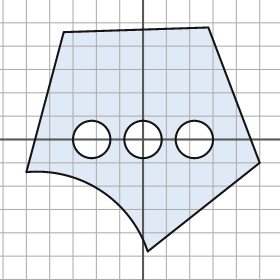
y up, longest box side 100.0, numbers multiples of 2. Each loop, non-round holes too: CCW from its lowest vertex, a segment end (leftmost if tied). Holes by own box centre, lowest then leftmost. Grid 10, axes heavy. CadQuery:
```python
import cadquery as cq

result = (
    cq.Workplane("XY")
    .moveTo(2.0, -48.0)
    .lineTo(50.0, -10.0)
    .lineTo(28.0, 48.0)
    .lineTo(-34.0, 46.0)
    .lineTo(-50.0, -14.0)
    .threePointArc((-18.0, -22.0), (2.0, -48.0))
    .close()
    .moveTo(-22.0, 0.0)
    .circle(8.0)
    .moveTo(0.0, 0.0)
    .circle(8.0)
    .moveTo(22.0, 0.0)
    .circle(8.0)
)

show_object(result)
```